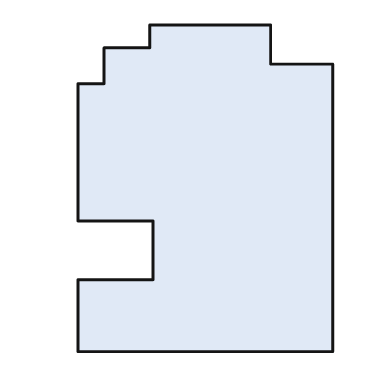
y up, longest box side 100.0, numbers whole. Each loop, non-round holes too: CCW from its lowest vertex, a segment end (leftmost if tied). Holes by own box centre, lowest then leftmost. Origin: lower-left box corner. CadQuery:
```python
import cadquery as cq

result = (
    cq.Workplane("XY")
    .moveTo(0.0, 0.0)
    .lineTo(78.0, 0.0)
    .lineTo(78.0, 88.0)
    .lineTo(59.0, 88.0)
    .lineTo(59.0, 100.0)
    .lineTo(22.0, 100.0)
    .lineTo(22.0, 93.0)
    .lineTo(8.0, 93.0)
    .lineTo(8.0, 82.0)
    .lineTo(0.0, 82.0)
    .lineTo(0.0, 40.0)
    .lineTo(23.0, 40.0)
    .lineTo(23.0, 22.0)
    .lineTo(0.0, 22.0)
    .close()
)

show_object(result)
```